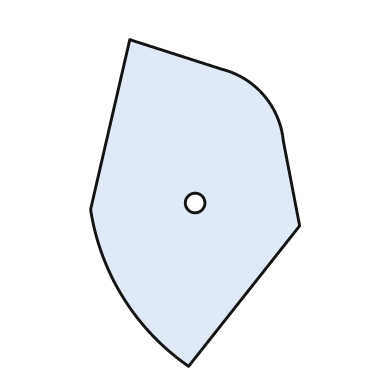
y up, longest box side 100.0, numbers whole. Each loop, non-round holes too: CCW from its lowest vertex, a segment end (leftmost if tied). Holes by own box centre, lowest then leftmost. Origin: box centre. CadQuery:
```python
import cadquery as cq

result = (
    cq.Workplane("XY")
    .moveTo(-2.0, -50.0)
    .lineTo(32.0, -7.0)
    .lineTo(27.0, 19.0)
    .threePointArc((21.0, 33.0), (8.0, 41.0))
    .lineTo(-20.0, 50.0)
    .lineTo(-32.0, -2.0)
    .threePointArc((-22.0, -29.0), (-2.0, -50.0))
    .close()
    .moveTo(0.0, 0.0)
    .circle(3.0)
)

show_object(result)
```